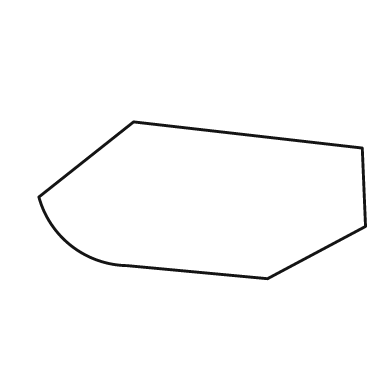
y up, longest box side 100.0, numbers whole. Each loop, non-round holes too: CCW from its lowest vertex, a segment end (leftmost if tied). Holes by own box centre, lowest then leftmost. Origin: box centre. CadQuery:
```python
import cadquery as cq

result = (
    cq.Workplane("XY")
    .moveTo(20.0, -24.0)
    .lineTo(50.0, -8.0)
    .lineTo(49.0, 16.0)
    .lineTo(-21.0, 24.0)
    .lineTo(-50.0, 1.0)
    .threePointArc((-40.0, -14.0), (-23.0, -20.0))
    .close()
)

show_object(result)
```